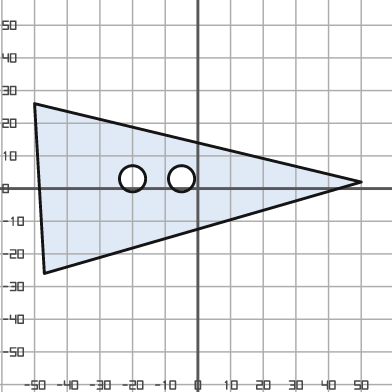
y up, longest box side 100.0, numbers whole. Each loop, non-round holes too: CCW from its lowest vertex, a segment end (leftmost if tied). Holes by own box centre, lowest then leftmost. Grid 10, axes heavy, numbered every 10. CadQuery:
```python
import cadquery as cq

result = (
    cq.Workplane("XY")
    .moveTo(-47.0, -26.0)
    .lineTo(50.0, 2.0)
    .lineTo(-50.0, 26.0)
    .close()
    .moveTo(-20.0, 3.0)
    .circle(4.0)
    .moveTo(-5.0, 3.0)
    .circle(4.0)
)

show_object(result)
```